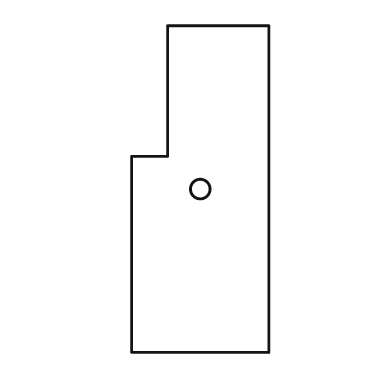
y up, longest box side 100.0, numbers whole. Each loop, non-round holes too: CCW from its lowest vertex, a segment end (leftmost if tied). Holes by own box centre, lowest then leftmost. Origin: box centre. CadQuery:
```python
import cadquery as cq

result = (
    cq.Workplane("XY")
    .moveTo(-21.0, -50.0)
    .lineTo(21.0, -50.0)
    .lineTo(21.0, 50.0)
    .lineTo(-10.0, 50.0)
    .lineTo(-10.0, 10.0)
    .lineTo(-21.0, 10.0)
    .close()
    .moveTo(0.0, 0.0)
    .circle(3.0)
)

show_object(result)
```